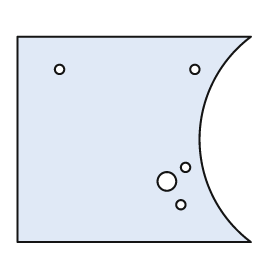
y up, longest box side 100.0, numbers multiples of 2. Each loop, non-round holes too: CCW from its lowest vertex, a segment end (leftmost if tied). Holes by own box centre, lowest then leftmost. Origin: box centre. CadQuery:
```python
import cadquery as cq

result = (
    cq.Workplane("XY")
    .moveTo(-50.0, -44.0)
    .lineTo(50.0, -44.0)
    .threePointArc((28.0, 0.0), (50.0, 44.0))
    .lineTo(-50.0, 44.0)
    .close()
    .moveTo(20.0, -28.0)
    .circle(2.0)
    .moveTo(14.0, -18.0)
    .circle(4.0)
    .moveTo(22.0, -12.0)
    .circle(2.0)
    .moveTo(-32.0, 30.0)
    .circle(2.0)
    .moveTo(26.0, 30.0)
    .circle(2.0)
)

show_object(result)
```